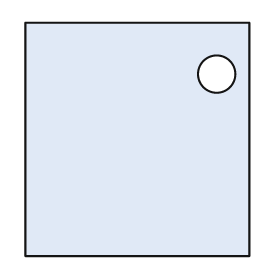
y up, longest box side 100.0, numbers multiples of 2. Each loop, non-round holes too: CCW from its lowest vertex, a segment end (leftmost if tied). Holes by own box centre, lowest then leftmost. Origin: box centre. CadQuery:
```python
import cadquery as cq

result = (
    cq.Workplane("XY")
    .moveTo(-48.0, -50.0)
    .lineTo(48.0, -50.0)
    .lineTo(48.0, 50.0)
    .lineTo(-48.0, 50.0)
    .close()
    .moveTo(34.0, 28.0)
    .circle(8.0)
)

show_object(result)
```